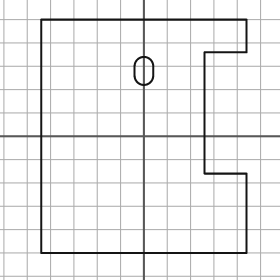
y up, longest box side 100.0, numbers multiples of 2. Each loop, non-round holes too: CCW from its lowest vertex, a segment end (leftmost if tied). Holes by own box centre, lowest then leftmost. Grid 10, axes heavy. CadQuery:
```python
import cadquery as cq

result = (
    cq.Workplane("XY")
    .moveTo(-44.0, -50.0)
    .lineTo(44.0, -50.0)
    .lineTo(44.0, -16.0)
    .lineTo(26.0, -16.0)
    .lineTo(26.0, 36.0)
    .lineTo(44.0, 36.0)
    .lineTo(44.0, 50.0)
    .lineTo(-44.0, 50.0)
    .close()
    .moveTo(-4.0, 26.0)
    .threePointArc((0.0, 22.0), (4.0, 26.0))
    .lineTo(4.0, 30.0)
    .threePointArc((0.0, 34.0), (-4.0, 30.0))
    .close()
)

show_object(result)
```